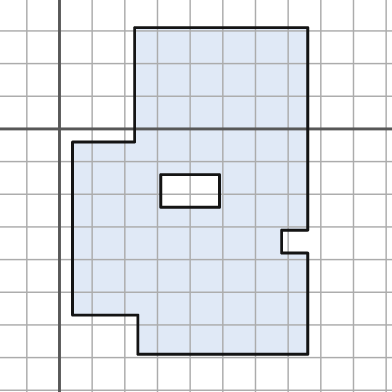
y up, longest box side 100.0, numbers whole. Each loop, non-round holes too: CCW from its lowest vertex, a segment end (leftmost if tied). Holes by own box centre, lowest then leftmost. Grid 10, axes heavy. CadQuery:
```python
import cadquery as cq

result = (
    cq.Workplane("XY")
    .moveTo(24.0, -69.0)
    .lineTo(76.0, -69.0)
    .lineTo(76.0, -38.0)
    .lineTo(68.0, -38.0)
    .lineTo(68.0, -31.0)
    .lineTo(76.0, -31.0)
    .lineTo(76.0, 31.0)
    .lineTo(23.0, 31.0)
    .lineTo(23.0, -4.0)
    .lineTo(4.0, -4.0)
    .lineTo(4.0, -57.0)
    .lineTo(24.0, -57.0)
    .close()
    .moveTo(31.0, -24.0)
    .lineTo(49.0, -24.0)
    .lineTo(49.0, -14.0)
    .lineTo(31.0, -14.0)
    .close()
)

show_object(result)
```